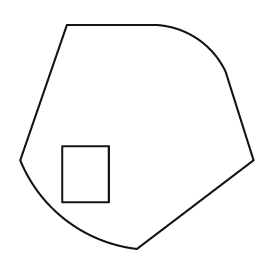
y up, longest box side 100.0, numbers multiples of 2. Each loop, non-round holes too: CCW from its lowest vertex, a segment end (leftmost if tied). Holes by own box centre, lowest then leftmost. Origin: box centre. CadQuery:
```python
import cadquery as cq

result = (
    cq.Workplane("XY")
    .moveTo(0.0, -48.0)
    .lineTo(50.0, -10.0)
    .lineTo(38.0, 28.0)
    .threePointArc((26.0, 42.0), (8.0, 48.0))
    .lineTo(-30.0, 48.0)
    .lineTo(-50.0, -10.0)
    .threePointArc((-30.0, -36.0), (0.0, -48.0))
    .close()
    .moveTo(-32.0, -28.0)
    .lineTo(-12.0, -28.0)
    .lineTo(-12.0, -4.0)
    .lineTo(-32.0, -4.0)
    .close()
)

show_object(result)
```